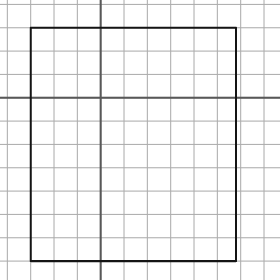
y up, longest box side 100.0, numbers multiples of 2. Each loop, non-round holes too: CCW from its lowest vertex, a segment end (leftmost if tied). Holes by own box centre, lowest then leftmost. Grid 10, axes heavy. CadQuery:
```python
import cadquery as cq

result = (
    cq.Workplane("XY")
    .moveTo(-30.0, -70.0)
    .lineTo(58.0, -70.0)
    .lineTo(58.0, 30.0)
    .lineTo(-30.0, 30.0)
    .close()
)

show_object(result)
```